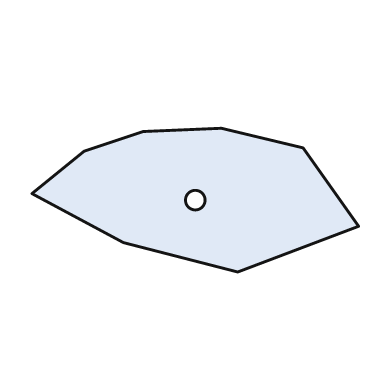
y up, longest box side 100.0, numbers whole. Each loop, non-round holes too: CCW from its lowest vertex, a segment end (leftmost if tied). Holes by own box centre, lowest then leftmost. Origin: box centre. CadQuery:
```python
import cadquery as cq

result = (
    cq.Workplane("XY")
    .moveTo(13.0, -22.0)
    .lineTo(50.0, -8.0)
    .lineTo(33.0, 16.0)
    .lineTo(8.0, 22.0)
    .lineTo(-16.0, 21.0)
    .lineTo(-34.0, 15.0)
    .lineTo(-50.0, 2.0)
    .lineTo(-22.0, -13.0)
    .close()
    .moveTo(0.0, 0.0)
    .circle(3.0)
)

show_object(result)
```